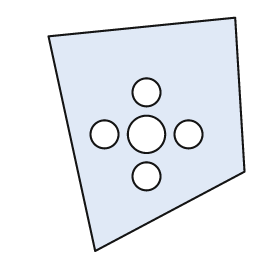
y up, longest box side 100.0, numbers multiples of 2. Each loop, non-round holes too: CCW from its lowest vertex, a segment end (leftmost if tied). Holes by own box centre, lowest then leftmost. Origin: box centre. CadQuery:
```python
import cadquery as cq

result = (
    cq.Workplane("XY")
    .moveTo(-22.0, -50.0)
    .lineTo(42.0, -16.0)
    .lineTo(38.0, 50.0)
    .lineTo(-42.0, 42.0)
    .close()
    .moveTo(0.0, -18.0)
    .circle(6.0)
    .moveTo(-18.0, 0.0)
    .circle(6.0)
    .moveTo(0.0, 0.0)
    .circle(8.0)
    .moveTo(18.0, 0.0)
    .circle(6.0)
    .moveTo(0.0, 18.0)
    .circle(6.0)
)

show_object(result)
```